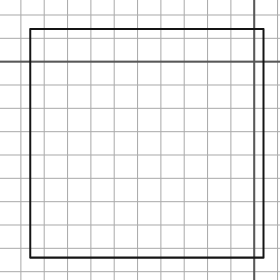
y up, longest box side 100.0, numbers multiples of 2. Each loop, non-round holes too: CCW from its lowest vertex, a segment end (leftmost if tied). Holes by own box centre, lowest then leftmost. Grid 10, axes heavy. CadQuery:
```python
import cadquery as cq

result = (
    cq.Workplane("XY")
    .moveTo(-96.0, -84.0)
    .lineTo(4.0, -84.0)
    .lineTo(4.0, 14.0)
    .lineTo(-96.0, 14.0)
    .close()
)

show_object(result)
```